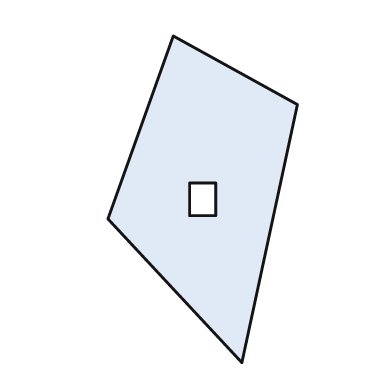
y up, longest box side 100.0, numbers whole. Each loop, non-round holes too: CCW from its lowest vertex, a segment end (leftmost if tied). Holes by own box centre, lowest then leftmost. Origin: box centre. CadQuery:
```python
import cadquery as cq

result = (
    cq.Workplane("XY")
    .moveTo(12.0, -50.0)
    .lineTo(29.0, 29.0)
    .lineTo(-9.0, 50.0)
    .lineTo(-29.0, -6.0)
    .close()
    .moveTo(-4.0, -5.0)
    .lineTo(4.0, -5.0)
    .lineTo(4.0, 5.0)
    .lineTo(-4.0, 5.0)
    .close()
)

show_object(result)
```